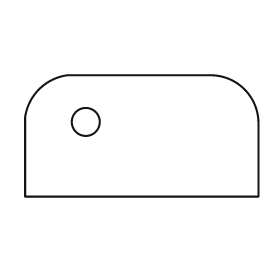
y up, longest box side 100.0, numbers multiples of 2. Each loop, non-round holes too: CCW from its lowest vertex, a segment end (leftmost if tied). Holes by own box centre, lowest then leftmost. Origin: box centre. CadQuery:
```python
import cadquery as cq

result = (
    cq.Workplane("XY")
    .moveTo(-50.0, -26.0)
    .lineTo(50.0, -26.0)
    .lineTo(50.0, 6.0)
    .threePointArc((44.0, 20.0), (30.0, 26.0))
    .lineTo(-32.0, 26.0)
    .threePointArc((-44.0, 20.0), (-50.0, 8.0))
    .close()
    .moveTo(-24.0, 6.0)
    .circle(6.0)
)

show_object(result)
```